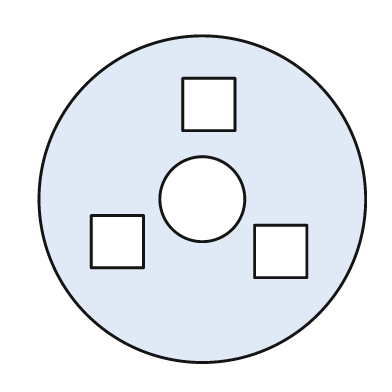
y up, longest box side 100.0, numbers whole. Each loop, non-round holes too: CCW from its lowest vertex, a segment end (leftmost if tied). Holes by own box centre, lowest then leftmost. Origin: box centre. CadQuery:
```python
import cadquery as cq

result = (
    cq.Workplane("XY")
    .moveTo(0.0, 0.0)
    .circle(50.0)
    .moveTo(16.0, -24.0)
    .lineTo(32.0, -24.0)
    .lineTo(32.0, -8.0)
    .lineTo(16.0, -8.0)
    .close()
    .moveTo(-34.0, -21.0)
    .lineTo(-18.0, -21.0)
    .lineTo(-18.0, -5.0)
    .lineTo(-34.0, -5.0)
    .close()
    .moveTo(0.0, 0.0)
    .circle(13.0)
    .moveTo(-6.0, 21.0)
    .lineTo(10.0, 21.0)
    .lineTo(10.0, 37.0)
    .lineTo(-6.0, 37.0)
    .close()
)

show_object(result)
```